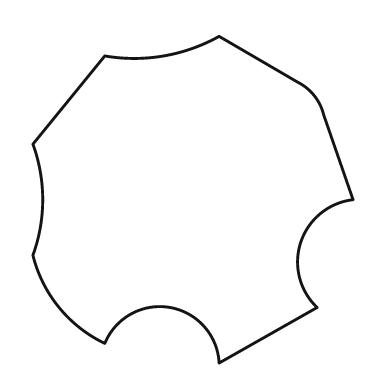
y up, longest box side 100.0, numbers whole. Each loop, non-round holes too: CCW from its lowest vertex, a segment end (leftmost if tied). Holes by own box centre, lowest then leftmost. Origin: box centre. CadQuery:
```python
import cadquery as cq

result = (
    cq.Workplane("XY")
    .moveTo(8.0, -50.0)
    .lineTo(38.0, -33.0)
    .threePointArc((33.0, -13.0), (49.0, 0.0))
    .lineTo(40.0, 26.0)
    .threePointArc((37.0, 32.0), (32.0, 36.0))
    .lineTo(8.0, 50.0)
    .threePointArc((-9.0, 44.0), (-27.0, 44.0))
    .lineTo(-49.0, 17.0)
    .threePointArc((-46.0, 0.0), (-49.0, -17.0))
    .threePointArc((-41.0, -33.0), (-27.0, -44.0))
    .threePointArc((-7.0, -33.0), (8.0, -50.0))
    .close()
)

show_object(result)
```